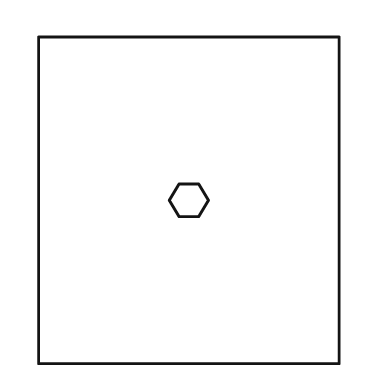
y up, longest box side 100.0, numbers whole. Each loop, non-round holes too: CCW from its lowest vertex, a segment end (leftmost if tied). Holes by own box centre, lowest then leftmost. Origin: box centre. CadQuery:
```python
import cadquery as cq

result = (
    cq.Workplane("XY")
    .moveTo(-46.0, -50.0)
    .lineTo(46.0, -50.0)
    .lineTo(46.0, 50.0)
    .lineTo(-46.0, 50.0)
    .close()
    .moveTo(-3.0, -5.0)
    .lineTo(3.0, -5.0)
    .lineTo(6.0, 0.0)
    .lineTo(3.0, 5.0)
    .lineTo(-3.0, 5.0)
    .lineTo(-6.0, 0.0)
    .close()
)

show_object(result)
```